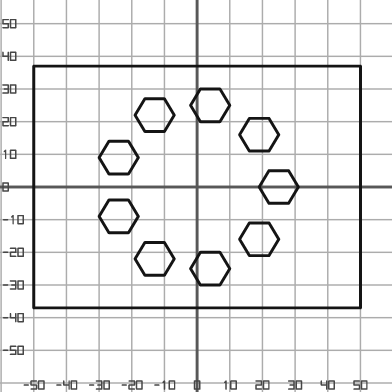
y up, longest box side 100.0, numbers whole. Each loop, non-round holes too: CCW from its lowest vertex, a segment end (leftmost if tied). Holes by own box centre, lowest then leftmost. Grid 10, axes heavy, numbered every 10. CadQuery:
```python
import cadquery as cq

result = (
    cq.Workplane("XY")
    .moveTo(-50.0, -37.0)
    .lineTo(50.0, -37.0)
    .lineTo(50.0, 37.0)
    .lineTo(-50.0, 37.0)
    .close()
    .moveTo(1.0, -30.0)
    .lineTo(7.0, -30.0)
    .lineTo(10.0, -25.0)
    .lineTo(7.0, -20.0)
    .lineTo(1.0, -20.0)
    .lineTo(-2.0, -25.0)
    .close()
    .moveTo(-16.0, -27.0)
    .lineTo(-10.0, -27.0)
    .lineTo(-7.0, -22.0)
    .lineTo(-10.0, -17.0)
    .lineTo(-16.0, -17.0)
    .lineTo(-19.0, -22.0)
    .close()
    .moveTo(16.0, -21.0)
    .lineTo(22.0, -21.0)
    .lineTo(25.0, -16.0)
    .lineTo(22.0, -11.0)
    .lineTo(16.0, -11.0)
    .lineTo(13.0, -16.0)
    .close()
    .moveTo(-27.0, -14.0)
    .lineTo(-21.0, -14.0)
    .lineTo(-18.0, -9.0)
    .lineTo(-21.0, -4.0)
    .lineTo(-27.0, -4.0)
    .lineTo(-30.0, -9.0)
    .close()
    .moveTo(22.0, -5.0)
    .lineTo(28.0, -5.0)
    .lineTo(31.0, 0.0)
    .lineTo(28.0, 5.0)
    .lineTo(22.0, 5.0)
    .lineTo(19.0, 0.0)
    .close()
    .moveTo(-27.0, 4.0)
    .lineTo(-21.0, 4.0)
    .lineTo(-18.0, 9.0)
    .lineTo(-21.0, 14.0)
    .lineTo(-27.0, 14.0)
    .lineTo(-30.0, 9.0)
    .close()
    .moveTo(16.0, 11.0)
    .lineTo(22.0, 11.0)
    .lineTo(25.0, 16.0)
    .lineTo(22.0, 21.0)
    .lineTo(16.0, 21.0)
    .lineTo(13.0, 16.0)
    .close()
    .moveTo(-16.0, 17.0)
    .lineTo(-10.0, 17.0)
    .lineTo(-7.0, 22.0)
    .lineTo(-10.0, 27.0)
    .lineTo(-16.0, 27.0)
    .lineTo(-19.0, 22.0)
    .close()
    .moveTo(1.0, 20.0)
    .lineTo(7.0, 20.0)
    .lineTo(10.0, 25.0)
    .lineTo(7.0, 30.0)
    .lineTo(1.0, 30.0)
    .lineTo(-2.0, 25.0)
    .close()
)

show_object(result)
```